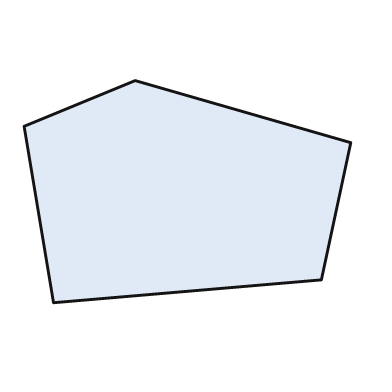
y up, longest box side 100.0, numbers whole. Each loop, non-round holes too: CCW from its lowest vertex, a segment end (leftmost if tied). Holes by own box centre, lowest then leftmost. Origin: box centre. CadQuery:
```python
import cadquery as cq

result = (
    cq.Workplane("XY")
    .moveTo(-41.0, -34.0)
    .lineTo(41.0, -27.0)
    .lineTo(50.0, 15.0)
    .lineTo(-16.0, 34.0)
    .lineTo(-50.0, 20.0)
    .close()
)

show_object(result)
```